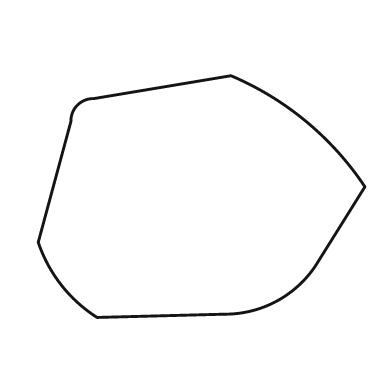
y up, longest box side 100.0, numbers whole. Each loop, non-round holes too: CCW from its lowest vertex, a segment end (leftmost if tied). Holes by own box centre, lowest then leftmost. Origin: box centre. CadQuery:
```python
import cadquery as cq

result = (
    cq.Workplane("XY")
    .moveTo(-32.0, -37.0)
    .lineTo(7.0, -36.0)
    .threePointArc((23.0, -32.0), (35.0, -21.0))
    .lineTo(50.0, 3.0)
    .threePointArc((32.0, 23.0), (9.0, 37.0))
    .lineTo(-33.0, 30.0)
    .threePointArc((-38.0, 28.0), (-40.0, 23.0))
    .lineTo(-50.0, -14.0)
    .threePointArc((-43.0, -27.0), (-32.0, -37.0))
    .close()
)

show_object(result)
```